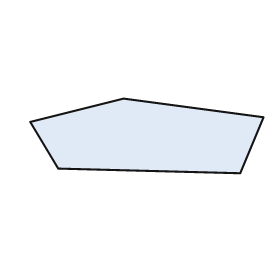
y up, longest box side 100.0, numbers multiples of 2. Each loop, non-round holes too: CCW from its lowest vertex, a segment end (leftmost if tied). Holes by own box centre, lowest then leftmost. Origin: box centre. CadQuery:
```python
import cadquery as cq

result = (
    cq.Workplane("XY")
    .moveTo(40.0, -16.0)
    .lineTo(50.0, 8.0)
    .lineTo(-10.0, 16.0)
    .lineTo(-50.0, 6.0)
    .lineTo(-38.0, -14.0)
    .close()
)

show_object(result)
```